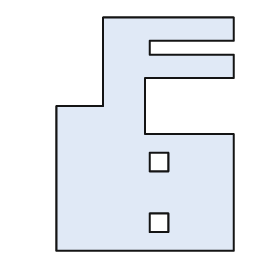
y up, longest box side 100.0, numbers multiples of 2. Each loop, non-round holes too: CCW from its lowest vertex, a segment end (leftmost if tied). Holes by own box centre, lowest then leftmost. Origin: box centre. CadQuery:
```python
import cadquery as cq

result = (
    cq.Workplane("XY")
    .moveTo(-38.0, -50.0)
    .lineTo(38.0, -50.0)
    .lineTo(38.0, 0.0)
    .lineTo(0.0, 0.0)
    .lineTo(0.0, 24.0)
    .lineTo(38.0, 24.0)
    .lineTo(38.0, 34.0)
    .lineTo(2.0, 34.0)
    .lineTo(2.0, 40.0)
    .lineTo(38.0, 40.0)
    .lineTo(38.0, 50.0)
    .lineTo(-18.0, 50.0)
    .lineTo(-18.0, 12.0)
    .lineTo(-38.0, 12.0)
    .close()
    .moveTo(2.0, -42.0)
    .lineTo(10.0, -42.0)
    .lineTo(10.0, -34.0)
    .lineTo(2.0, -34.0)
    .close()
    .moveTo(2.0, -16.0)
    .lineTo(10.0, -16.0)
    .lineTo(10.0, -8.0)
    .lineTo(2.0, -8.0)
    .close()
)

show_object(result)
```